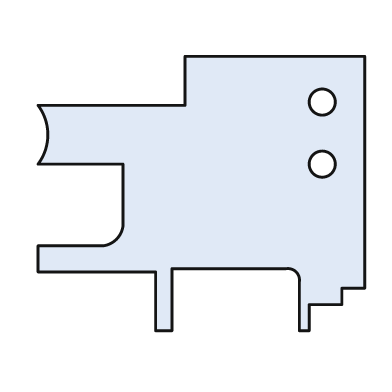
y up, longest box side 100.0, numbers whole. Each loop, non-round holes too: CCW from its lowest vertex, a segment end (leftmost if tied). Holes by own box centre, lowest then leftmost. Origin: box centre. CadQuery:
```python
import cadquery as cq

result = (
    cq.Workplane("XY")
    .moveTo(-14.0, -42.0)
    .lineTo(-9.0, -42.0)
    .lineTo(-9.0, -23.0)
    .lineTo(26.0, -23.0)
    .threePointArc((29.0, -24.0), (30.0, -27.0))
    .lineTo(30.0, -42.0)
    .lineTo(33.0, -42.0)
    .lineTo(33.0, -34.0)
    .lineTo(43.0, -34.0)
    .lineTo(43.0, -29.0)
    .lineTo(50.0, -29.0)
    .lineTo(50.0, 42.0)
    .lineTo(-5.0, 42.0)
    .lineTo(-5.0, 27.0)
    .lineTo(-50.0, 27.0)
    .threePointArc((-47.0, 18.0), (-50.0, 9.0))
    .lineTo(-24.0, 9.0)
    .lineTo(-24.0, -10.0)
    .threePointArc((-26.0, -14.0), (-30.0, -16.0))
    .lineTo(-50.0, -16.0)
    .lineTo(-50.0, -24.0)
    .lineTo(-14.0, -24.0)
    .close()
    .moveTo(37.0, 9.0)
    .circle(4.0)
    .moveTo(37.0, 28.0)
    .circle(4.0)
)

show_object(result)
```